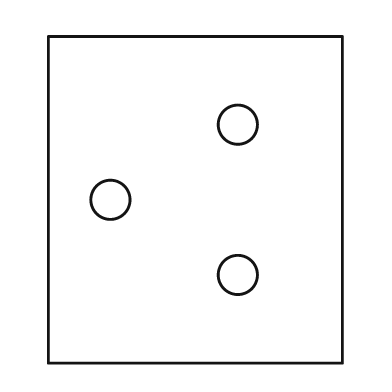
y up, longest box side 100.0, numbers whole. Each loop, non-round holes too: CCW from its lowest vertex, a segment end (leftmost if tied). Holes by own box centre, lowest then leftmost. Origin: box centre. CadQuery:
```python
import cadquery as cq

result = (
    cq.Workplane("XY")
    .moveTo(-45.0, -50.0)
    .lineTo(45.0, -50.0)
    .lineTo(45.0, 50.0)
    .lineTo(-45.0, 50.0)
    .close()
    .moveTo(13.0, -23.0)
    .circle(6.0)
    .moveTo(-26.0, 0.0)
    .circle(6.0)
    .moveTo(13.0, 23.0)
    .circle(6.0)
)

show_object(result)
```